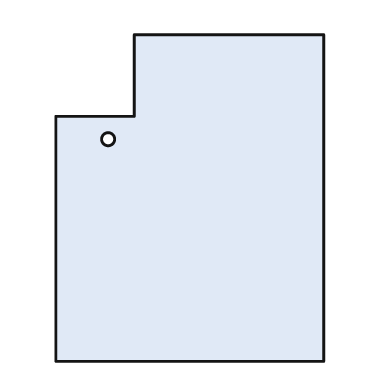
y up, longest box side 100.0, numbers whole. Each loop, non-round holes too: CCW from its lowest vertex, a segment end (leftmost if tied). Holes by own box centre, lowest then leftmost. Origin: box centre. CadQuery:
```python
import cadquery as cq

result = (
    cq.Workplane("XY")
    .moveTo(-41.0, -50.0)
    .lineTo(41.0, -50.0)
    .lineTo(41.0, 50.0)
    .lineTo(-17.0, 50.0)
    .lineTo(-17.0, 25.0)
    .lineTo(-41.0, 25.0)
    .close()
    .moveTo(-25.0, 18.0)
    .circle(2.0)
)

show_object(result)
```